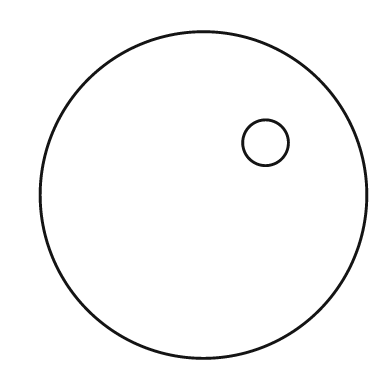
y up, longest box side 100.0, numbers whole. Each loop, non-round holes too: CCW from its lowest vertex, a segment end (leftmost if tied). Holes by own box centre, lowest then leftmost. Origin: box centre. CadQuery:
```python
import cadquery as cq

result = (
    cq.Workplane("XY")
    .moveTo(0.0, 0.0)
    .circle(50.0)
    .moveTo(19.0, 16.0)
    .circle(7.0)
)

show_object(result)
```